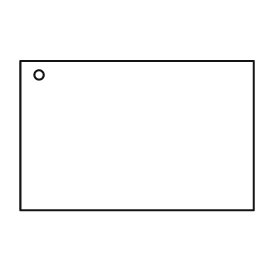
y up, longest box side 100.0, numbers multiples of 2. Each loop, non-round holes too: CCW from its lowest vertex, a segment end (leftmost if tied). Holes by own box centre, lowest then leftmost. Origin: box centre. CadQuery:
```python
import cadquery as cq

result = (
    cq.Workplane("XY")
    .moveTo(-50.0, -32.0)
    .lineTo(50.0, -32.0)
    .lineTo(50.0, 32.0)
    .lineTo(-50.0, 32.0)
    .close()
    .moveTo(-42.0, 26.0)
    .circle(2.0)
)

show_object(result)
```